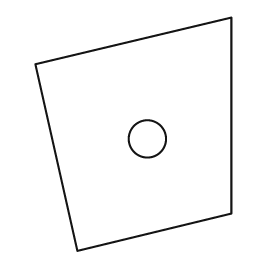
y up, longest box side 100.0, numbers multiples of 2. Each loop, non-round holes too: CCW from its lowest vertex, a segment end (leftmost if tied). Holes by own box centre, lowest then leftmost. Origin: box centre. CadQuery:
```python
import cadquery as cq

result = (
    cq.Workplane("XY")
    .moveTo(-24.0, -50.0)
    .lineTo(42.0, -34.0)
    .lineTo(42.0, 50.0)
    .lineTo(-42.0, 30.0)
    .close()
    .moveTo(6.0, -2.0)
    .circle(8.0)
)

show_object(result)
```